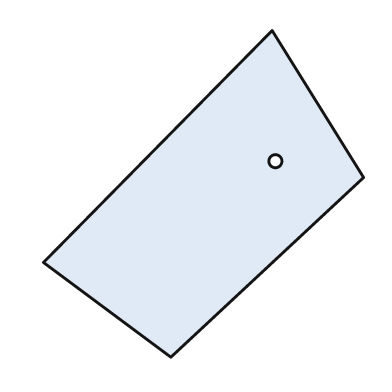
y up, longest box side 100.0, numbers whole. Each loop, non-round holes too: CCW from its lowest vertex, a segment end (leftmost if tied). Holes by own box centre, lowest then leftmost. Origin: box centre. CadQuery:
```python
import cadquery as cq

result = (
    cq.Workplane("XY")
    .moveTo(-10.0, -50.0)
    .lineTo(49.0, 5.0)
    .lineTo(21.0, 50.0)
    .lineTo(-49.0, -21.0)
    .close()
    .moveTo(22.0, 10.0)
    .circle(2.0)
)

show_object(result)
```